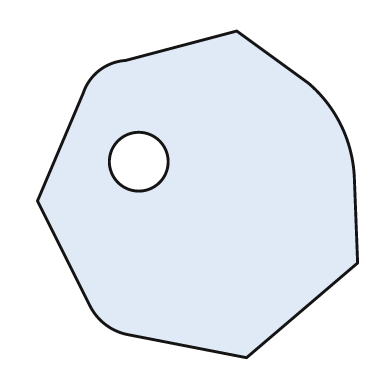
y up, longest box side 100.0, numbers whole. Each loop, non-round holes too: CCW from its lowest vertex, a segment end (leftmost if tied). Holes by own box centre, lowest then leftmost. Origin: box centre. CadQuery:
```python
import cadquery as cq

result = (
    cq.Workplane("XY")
    .moveTo(15.0, -50.0)
    .lineTo(49.0, -21.0)
    .lineTo(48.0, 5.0)
    .threePointArc((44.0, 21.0), (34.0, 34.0))
    .lineTo(12.0, 50.0)
    .lineTo(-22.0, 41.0)
    .threePointArc((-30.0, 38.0), (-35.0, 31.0))
    .lineTo(-49.0, -2.0)
    .lineTo(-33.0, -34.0)
    .threePointArc((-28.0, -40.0), (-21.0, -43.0))
    .close()
    .moveTo(-18.0, 10.0)
    .circle(9.0)
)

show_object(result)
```